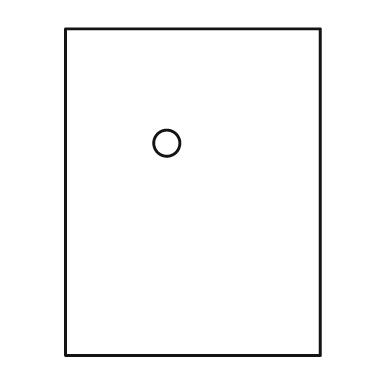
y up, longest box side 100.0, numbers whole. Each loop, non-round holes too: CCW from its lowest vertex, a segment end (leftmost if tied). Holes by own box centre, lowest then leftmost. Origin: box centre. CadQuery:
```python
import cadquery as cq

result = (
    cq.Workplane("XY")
    .moveTo(-39.0, -50.0)
    .lineTo(39.0, -50.0)
    .lineTo(39.0, 50.0)
    .lineTo(-39.0, 50.0)
    .close()
    .moveTo(-8.0, 15.0)
    .circle(4.0)
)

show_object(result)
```